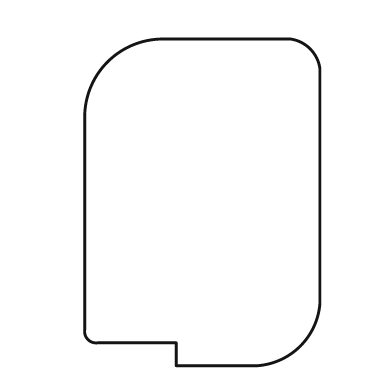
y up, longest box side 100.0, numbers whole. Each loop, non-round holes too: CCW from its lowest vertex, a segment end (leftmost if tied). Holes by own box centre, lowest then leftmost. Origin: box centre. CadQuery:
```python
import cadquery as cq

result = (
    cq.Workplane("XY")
    .moveTo(-8.0, -50.0)
    .lineTo(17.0, -50.0)
    .threePointArc((30.0, -44.0), (36.0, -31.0))
    .lineTo(36.0, 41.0)
    .threePointArc((33.0, 47.0), (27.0, 50.0))
    .lineTo(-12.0, 50.0)
    .threePointArc((-29.0, 43.0), (-36.0, 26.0))
    .lineTo(-36.0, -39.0)
    .threePointArc((-35.0, -42.0), (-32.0, -43.0))
    .lineTo(-8.0, -43.0)
    .close()
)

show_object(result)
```